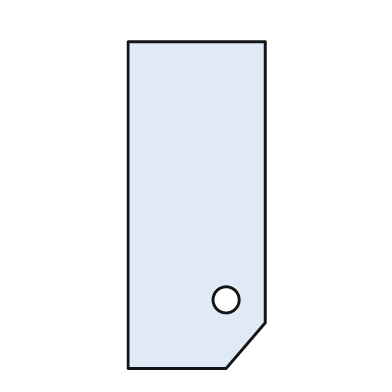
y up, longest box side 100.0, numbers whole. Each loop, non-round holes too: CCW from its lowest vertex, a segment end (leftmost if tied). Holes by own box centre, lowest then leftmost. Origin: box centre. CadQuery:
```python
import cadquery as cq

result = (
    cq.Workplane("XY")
    .moveTo(-21.0, -50.0)
    .lineTo(9.0, -50.0)
    .lineTo(21.0, -36.0)
    .lineTo(21.0, 50.0)
    .lineTo(-21.0, 50.0)
    .close()
    .moveTo(9.0, -29.0)
    .circle(4.0)
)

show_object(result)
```